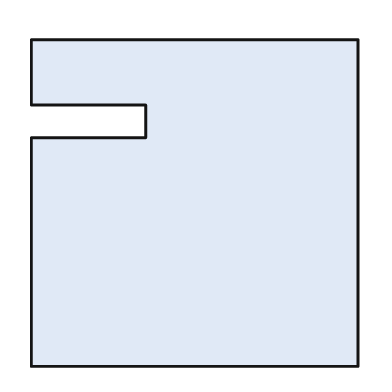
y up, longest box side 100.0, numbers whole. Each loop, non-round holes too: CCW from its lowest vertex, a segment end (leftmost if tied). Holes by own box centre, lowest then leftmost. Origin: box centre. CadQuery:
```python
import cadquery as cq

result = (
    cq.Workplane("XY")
    .moveTo(-50.0, -50.0)
    .lineTo(50.0, -50.0)
    .lineTo(50.0, 50.0)
    .lineTo(-50.0, 50.0)
    .lineTo(-50.0, 30.0)
    .lineTo(-15.0, 30.0)
    .lineTo(-15.0, 20.0)
    .lineTo(-50.0, 20.0)
    .close()
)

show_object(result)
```